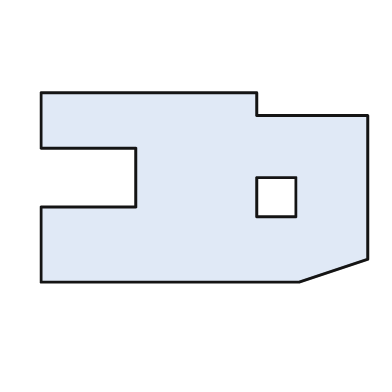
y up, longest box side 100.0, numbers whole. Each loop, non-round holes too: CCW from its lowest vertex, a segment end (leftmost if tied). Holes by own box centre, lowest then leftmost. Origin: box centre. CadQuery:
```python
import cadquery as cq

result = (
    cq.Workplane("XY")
    .moveTo(-50.0, -29.0)
    .lineTo(29.0, -29.0)
    .lineTo(50.0, -22.0)
    .lineTo(50.0, 22.0)
    .lineTo(16.0, 22.0)
    .lineTo(16.0, 29.0)
    .lineTo(-50.0, 29.0)
    .lineTo(-50.0, 12.0)
    .lineTo(-21.0, 12.0)
    .lineTo(-21.0, -6.0)
    .lineTo(-50.0, -6.0)
    .close()
    .moveTo(16.0, -9.0)
    .lineTo(28.0, -9.0)
    .lineTo(28.0, 3.0)
    .lineTo(16.0, 3.0)
    .close()
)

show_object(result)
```